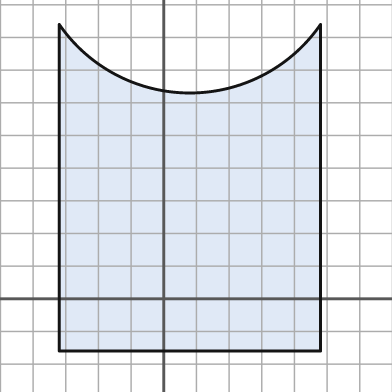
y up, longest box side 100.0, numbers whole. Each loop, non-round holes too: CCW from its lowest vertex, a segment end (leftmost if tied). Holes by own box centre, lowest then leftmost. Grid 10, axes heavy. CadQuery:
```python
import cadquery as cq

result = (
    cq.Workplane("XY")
    .moveTo(-32.0, -16.0)
    .lineTo(48.0, -16.0)
    .lineTo(48.0, 84.0)
    .threePointArc((8.0, 63.0), (-32.0, 84.0))
    .close()
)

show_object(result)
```